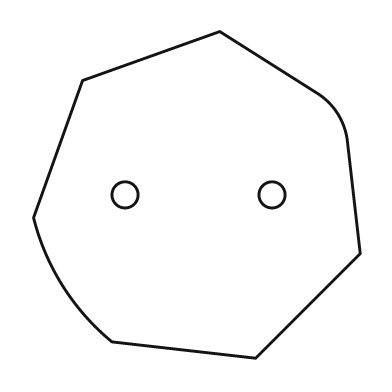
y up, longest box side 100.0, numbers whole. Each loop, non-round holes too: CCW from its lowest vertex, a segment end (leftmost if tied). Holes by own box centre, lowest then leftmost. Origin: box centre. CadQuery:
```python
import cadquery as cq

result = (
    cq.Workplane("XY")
    .moveTo(18.0, -50.0)
    .lineTo(50.0, -18.0)
    .lineTo(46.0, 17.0)
    .threePointArc((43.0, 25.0), (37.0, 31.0))
    .lineTo(7.0, 50.0)
    .lineTo(-35.0, 35.0)
    .lineTo(-50.0, -7.0)
    .threePointArc((-41.0, -28.0), (-26.0, -45.0))
    .close()
    .moveTo(-22.0, 0.0)
    .circle(4.0)
    .moveTo(23.0, 0.0)
    .circle(4.0)
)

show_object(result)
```